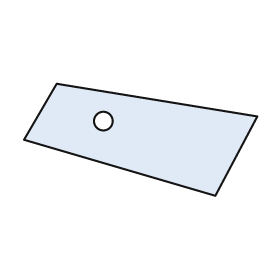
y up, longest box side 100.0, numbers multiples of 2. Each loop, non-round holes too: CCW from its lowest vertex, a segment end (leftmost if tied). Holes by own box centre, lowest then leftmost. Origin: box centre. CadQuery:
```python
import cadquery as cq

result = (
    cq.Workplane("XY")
    .moveTo(32.0, -24.0)
    .lineTo(50.0, 10.0)
    .lineTo(-36.0, 24.0)
    .lineTo(-50.0, 0.0)
    .close()
    .moveTo(-16.0, 8.0)
    .circle(4.0)
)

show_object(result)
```